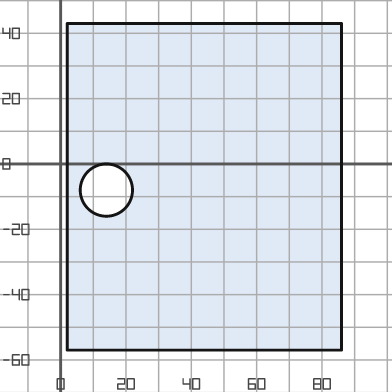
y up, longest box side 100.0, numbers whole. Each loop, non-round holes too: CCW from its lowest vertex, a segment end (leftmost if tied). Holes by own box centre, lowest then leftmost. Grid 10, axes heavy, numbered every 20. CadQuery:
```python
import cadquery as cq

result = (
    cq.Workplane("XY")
    .moveTo(2.0, -57.0)
    .lineTo(86.0, -57.0)
    .lineTo(86.0, 43.0)
    .lineTo(2.0, 43.0)
    .close()
    .moveTo(14.0, -8.0)
    .circle(8.0)
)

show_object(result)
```